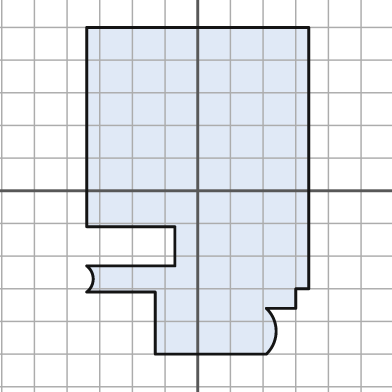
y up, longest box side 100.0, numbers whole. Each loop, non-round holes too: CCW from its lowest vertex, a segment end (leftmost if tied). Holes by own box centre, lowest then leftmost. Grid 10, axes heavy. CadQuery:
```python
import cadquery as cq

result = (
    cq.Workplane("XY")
    .moveTo(-13.0, -50.0)
    .lineTo(21.0, -50.0)
    .threePointArc((24.0, -43.0), (21.0, -36.0))
    .lineTo(30.0, -36.0)
    .lineTo(30.0, -30.0)
    .lineTo(34.0, -30.0)
    .lineTo(34.0, 50.0)
    .lineTo(-34.0, 50.0)
    .lineTo(-34.0, -11.0)
    .lineTo(-7.0, -11.0)
    .lineTo(-7.0, -23.0)
    .lineTo(-34.0, -23.0)
    .threePointArc((-32.0, -27.0), (-34.0, -31.0))
    .lineTo(-13.0, -31.0)
    .close()
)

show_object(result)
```